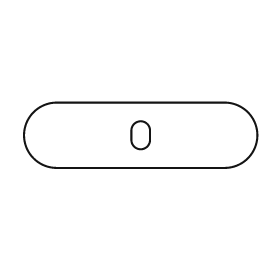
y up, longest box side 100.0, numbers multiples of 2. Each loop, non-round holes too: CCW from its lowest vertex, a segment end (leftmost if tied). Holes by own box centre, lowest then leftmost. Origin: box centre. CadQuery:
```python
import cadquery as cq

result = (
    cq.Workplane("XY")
    .moveTo(-36.0, -14.0)
    .lineTo(36.0, -14.0)
    .threePointArc((50.0, 0.0), (36.0, 14.0))
    .lineTo(-36.0, 14.0)
    .threePointArc((-50.0, 0.0), (-36.0, -14.0))
    .close()
    .moveTo(-4.0, -2.0)
    .threePointArc((0.0, -6.0), (4.0, -2.0))
    .lineTo(4.0, 2.0)
    .threePointArc((0.0, 6.0), (-4.0, 2.0))
    .close()
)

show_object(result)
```